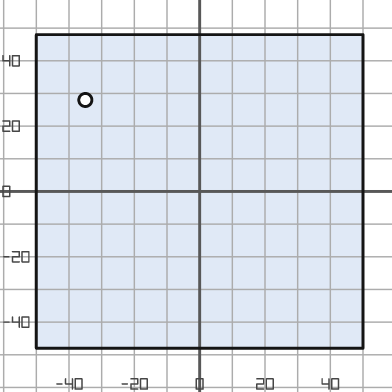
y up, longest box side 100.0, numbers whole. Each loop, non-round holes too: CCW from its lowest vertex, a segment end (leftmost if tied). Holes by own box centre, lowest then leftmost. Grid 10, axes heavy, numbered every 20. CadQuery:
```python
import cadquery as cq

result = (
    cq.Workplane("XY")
    .moveTo(-50.0, -48.0)
    .lineTo(50.0, -48.0)
    .lineTo(50.0, 48.0)
    .lineTo(-50.0, 48.0)
    .close()
    .moveTo(-35.0, 28.0)
    .circle(2.0)
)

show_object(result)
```